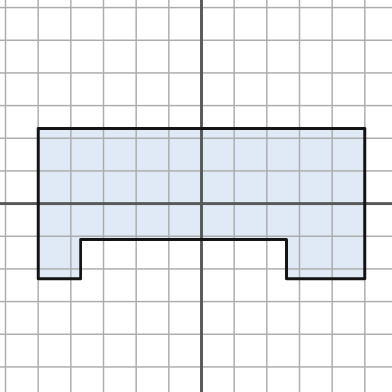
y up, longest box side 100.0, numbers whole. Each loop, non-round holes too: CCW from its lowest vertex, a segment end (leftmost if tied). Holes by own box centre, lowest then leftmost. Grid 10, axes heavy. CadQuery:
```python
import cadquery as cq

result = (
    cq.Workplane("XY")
    .moveTo(-50.0, -23.0)
    .lineTo(-37.0, -23.0)
    .lineTo(-37.0, -11.0)
    .lineTo(26.0, -11.0)
    .lineTo(26.0, -23.0)
    .lineTo(50.0, -23.0)
    .lineTo(50.0, 23.0)
    .lineTo(-50.0, 23.0)
    .close()
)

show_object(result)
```